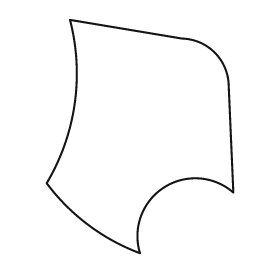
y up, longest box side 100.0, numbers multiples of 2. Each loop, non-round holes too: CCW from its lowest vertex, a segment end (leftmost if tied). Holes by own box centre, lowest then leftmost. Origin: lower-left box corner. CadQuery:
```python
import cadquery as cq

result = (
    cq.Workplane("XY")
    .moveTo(40.0, 0.0)
    .threePointArc((50.0, 28.0), (80.0, 26.0))
    .lineTo(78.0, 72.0)
    .threePointArc((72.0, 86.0), (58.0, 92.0))
    .lineTo(10.0, 100.0)
    .threePointArc((12.0, 64.0), (0.0, 30.0))
    .threePointArc((18.0, 12.0), (40.0, 0.0))
    .close()
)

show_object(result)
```